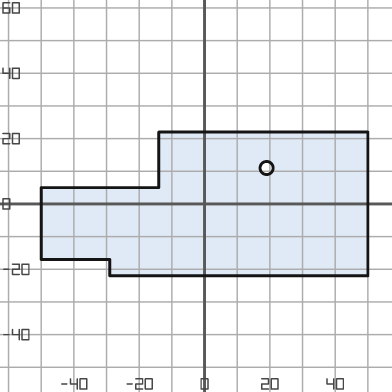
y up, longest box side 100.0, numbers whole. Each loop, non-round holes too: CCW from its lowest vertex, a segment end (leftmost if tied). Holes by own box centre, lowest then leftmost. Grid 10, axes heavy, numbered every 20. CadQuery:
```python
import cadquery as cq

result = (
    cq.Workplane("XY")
    .moveTo(-29.0, -22.0)
    .lineTo(50.0, -22.0)
    .lineTo(50.0, 22.0)
    .lineTo(-14.0, 22.0)
    .lineTo(-14.0, 5.0)
    .lineTo(-50.0, 5.0)
    .lineTo(-50.0, -17.0)
    .lineTo(-29.0, -17.0)
    .close()
    .moveTo(19.0, 11.0)
    .circle(2.0)
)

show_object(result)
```